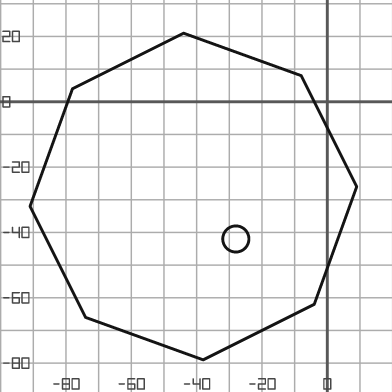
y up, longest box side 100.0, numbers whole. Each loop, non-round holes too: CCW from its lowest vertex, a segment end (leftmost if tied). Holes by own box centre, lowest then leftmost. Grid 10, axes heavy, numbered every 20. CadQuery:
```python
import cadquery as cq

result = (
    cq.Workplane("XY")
    .moveTo(-38.0, -79.0)
    .lineTo(-4.0, -62.0)
    .lineTo(9.0, -26.0)
    .lineTo(-8.0, 8.0)
    .lineTo(-44.0, 21.0)
    .lineTo(-78.0, 4.0)
    .lineTo(-91.0, -32.0)
    .lineTo(-74.0, -66.0)
    .close()
    .moveTo(-28.0, -42.0)
    .circle(4.0)
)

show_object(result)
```